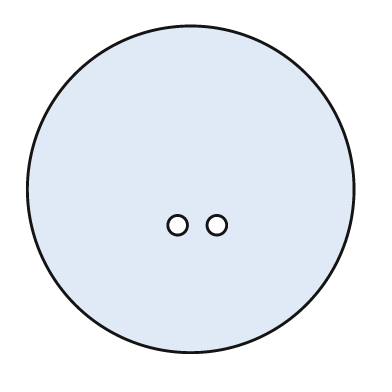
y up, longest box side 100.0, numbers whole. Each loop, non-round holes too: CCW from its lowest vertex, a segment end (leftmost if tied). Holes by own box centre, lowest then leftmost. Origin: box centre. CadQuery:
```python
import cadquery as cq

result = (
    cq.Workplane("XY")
    .moveTo(0.0, 0.0)
    .circle(50.0)
    .moveTo(-4.0, -11.0)
    .circle(3.0)
    .moveTo(8.0, -11.0)
    .circle(3.0)
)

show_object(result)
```